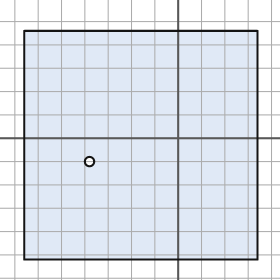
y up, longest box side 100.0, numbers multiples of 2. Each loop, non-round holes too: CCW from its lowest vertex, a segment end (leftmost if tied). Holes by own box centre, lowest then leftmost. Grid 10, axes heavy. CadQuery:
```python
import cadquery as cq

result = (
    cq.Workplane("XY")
    .moveTo(-66.0, -52.0)
    .lineTo(34.0, -52.0)
    .lineTo(34.0, 46.0)
    .lineTo(-66.0, 46.0)
    .close()
    .moveTo(-38.0, -10.0)
    .circle(2.0)
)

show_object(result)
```